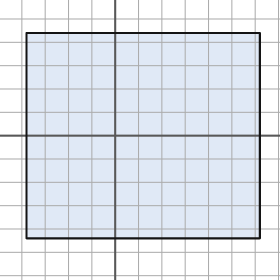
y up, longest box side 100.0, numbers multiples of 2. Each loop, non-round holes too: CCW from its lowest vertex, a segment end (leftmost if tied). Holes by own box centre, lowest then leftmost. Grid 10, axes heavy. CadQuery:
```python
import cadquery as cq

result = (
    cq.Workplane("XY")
    .moveTo(-38.0, -44.0)
    .lineTo(62.0, -44.0)
    .lineTo(62.0, 44.0)
    .lineTo(-38.0, 44.0)
    .close()
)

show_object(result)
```